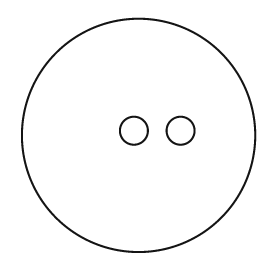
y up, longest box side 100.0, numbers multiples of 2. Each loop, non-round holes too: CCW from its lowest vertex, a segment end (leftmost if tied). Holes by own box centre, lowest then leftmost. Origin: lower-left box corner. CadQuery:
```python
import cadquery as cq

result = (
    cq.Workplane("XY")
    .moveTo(50.0, 50.0)
    .circle(50.0)
    .moveTo(48.0, 52.0)
    .circle(6.0)
    .moveTo(68.0, 52.0)
    .circle(6.0)
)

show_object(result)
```